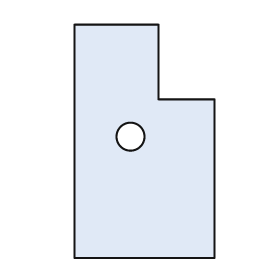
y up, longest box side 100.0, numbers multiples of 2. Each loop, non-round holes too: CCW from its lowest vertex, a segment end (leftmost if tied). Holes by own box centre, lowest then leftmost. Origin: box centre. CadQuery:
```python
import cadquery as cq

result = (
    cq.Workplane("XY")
    .moveTo(-30.0, -50.0)
    .lineTo(30.0, -50.0)
    .lineTo(30.0, 18.0)
    .lineTo(6.0, 18.0)
    .lineTo(6.0, 50.0)
    .lineTo(-30.0, 50.0)
    .close()
    .moveTo(-6.0, 2.0)
    .circle(6.0)
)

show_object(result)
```